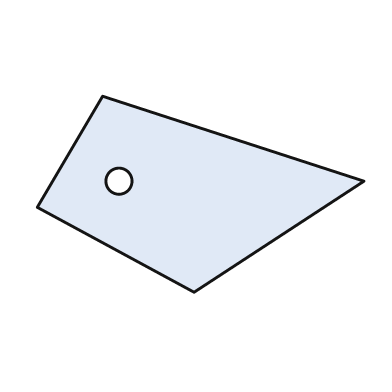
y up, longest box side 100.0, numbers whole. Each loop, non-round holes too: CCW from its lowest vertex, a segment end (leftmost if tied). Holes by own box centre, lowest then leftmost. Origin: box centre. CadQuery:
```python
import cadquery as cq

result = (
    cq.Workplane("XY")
    .moveTo(-2.0, -30.0)
    .lineTo(50.0, 4.0)
    .lineTo(-30.0, 30.0)
    .lineTo(-50.0, -4.0)
    .close()
    .moveTo(-25.0, 4.0)
    .circle(4.0)
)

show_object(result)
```